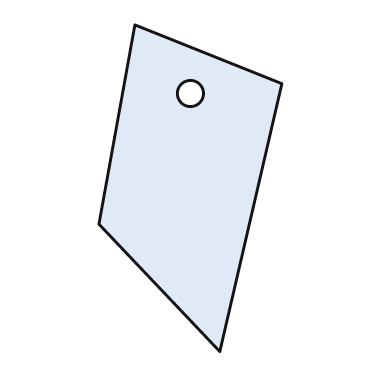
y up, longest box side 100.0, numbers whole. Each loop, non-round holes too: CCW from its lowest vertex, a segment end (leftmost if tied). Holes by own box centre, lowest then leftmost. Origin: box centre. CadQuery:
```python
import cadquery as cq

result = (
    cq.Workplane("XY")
    .moveTo(9.0, -50.0)
    .lineTo(28.0, 32.0)
    .lineTo(-17.0, 50.0)
    .lineTo(-28.0, -11.0)
    .close()
    .moveTo(0.0, 29.0)
    .circle(4.0)
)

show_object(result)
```